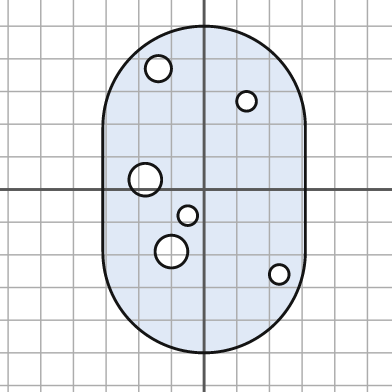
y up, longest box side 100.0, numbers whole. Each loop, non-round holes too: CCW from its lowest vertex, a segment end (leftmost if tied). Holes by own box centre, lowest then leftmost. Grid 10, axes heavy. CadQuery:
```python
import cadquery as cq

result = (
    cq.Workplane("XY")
    .moveTo(-31.0, -19.0)
    .threePointArc((0.0, -50.0), (31.0, -19.0))
    .lineTo(31.0, 19.0)
    .threePointArc((0.0, 50.0), (-31.0, 19.0))
    .close()
    .moveTo(23.0, -26.0)
    .circle(3.0)
    .moveTo(-10.0, -19.0)
    .circle(5.0)
    .moveTo(-5.0, -8.0)
    .circle(3.0)
    .moveTo(-18.0, 3.0)
    .circle(5.0)
    .moveTo(13.0, 27.0)
    .circle(3.0)
    .moveTo(-14.0, 37.0)
    .circle(4.0)
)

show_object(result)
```